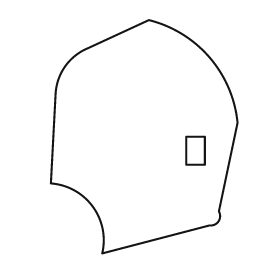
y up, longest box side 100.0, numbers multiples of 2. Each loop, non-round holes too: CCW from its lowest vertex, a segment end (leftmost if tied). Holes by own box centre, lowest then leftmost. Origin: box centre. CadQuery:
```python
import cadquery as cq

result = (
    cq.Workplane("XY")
    .moveTo(-18.0, -50.0)
    .lineTo(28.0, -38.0)
    .threePointArc((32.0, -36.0), (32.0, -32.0))
    .lineTo(40.0, 6.0)
    .threePointArc((28.0, 34.0), (2.0, 50.0))
    .lineTo(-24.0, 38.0)
    .threePointArc((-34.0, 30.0), (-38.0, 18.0))
    .lineTo(-40.0, -20.0)
    .threePointArc((-22.0, -30.0), (-18.0, -50.0))
    .close()
    .moveTo(18.0, -12.0)
    .lineTo(26.0, -12.0)
    .lineTo(26.0, 0.0)
    .lineTo(18.0, 0.0)
    .close()
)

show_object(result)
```